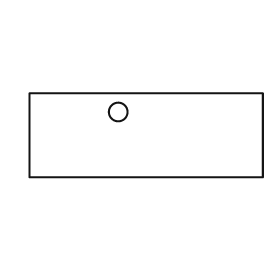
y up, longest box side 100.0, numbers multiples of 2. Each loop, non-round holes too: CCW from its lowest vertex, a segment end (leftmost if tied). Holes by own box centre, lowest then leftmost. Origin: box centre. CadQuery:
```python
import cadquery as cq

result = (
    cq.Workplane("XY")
    .moveTo(-50.0, -18.0)
    .lineTo(50.0, -18.0)
    .lineTo(50.0, 18.0)
    .lineTo(-50.0, 18.0)
    .close()
    .moveTo(-12.0, 10.0)
    .circle(4.0)
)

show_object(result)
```